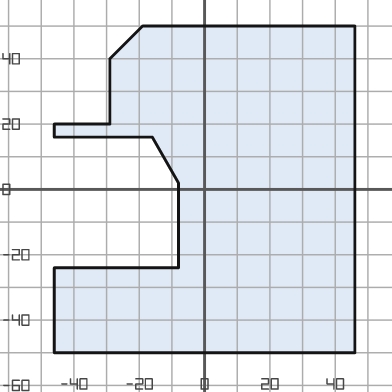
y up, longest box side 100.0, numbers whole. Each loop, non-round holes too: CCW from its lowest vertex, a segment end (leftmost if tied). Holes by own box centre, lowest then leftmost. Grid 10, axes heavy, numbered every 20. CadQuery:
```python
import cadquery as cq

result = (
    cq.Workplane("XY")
    .moveTo(-46.0, -50.0)
    .lineTo(46.0, -50.0)
    .lineTo(46.0, 50.0)
    .lineTo(-19.0, 50.0)
    .lineTo(-29.0, 40.0)
    .lineTo(-29.0, 20.0)
    .lineTo(-46.0, 20.0)
    .lineTo(-46.0, 16.0)
    .lineTo(-16.0, 16.0)
    .lineTo(-8.0, 2.0)
    .lineTo(-8.0, -24.0)
    .lineTo(-46.0, -24.0)
    .close()
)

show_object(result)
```